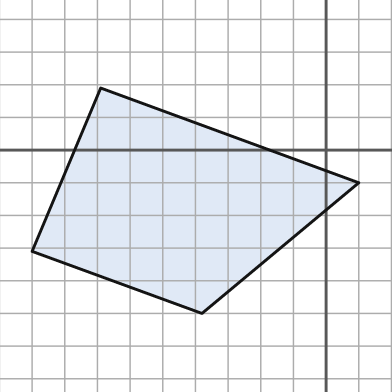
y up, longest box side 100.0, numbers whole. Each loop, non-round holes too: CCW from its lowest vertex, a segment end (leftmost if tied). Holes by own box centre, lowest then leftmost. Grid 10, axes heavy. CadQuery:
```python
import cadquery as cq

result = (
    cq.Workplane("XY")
    .moveTo(-38.0, -50.0)
    .lineTo(10.0, -10.0)
    .lineTo(-69.0, 19.0)
    .lineTo(-90.0, -31.0)
    .close()
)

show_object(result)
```